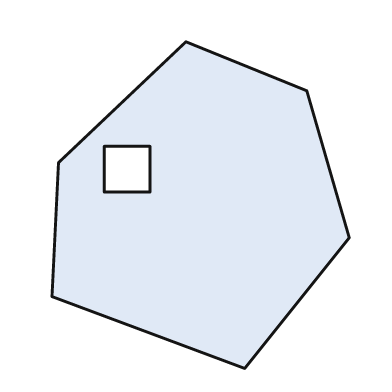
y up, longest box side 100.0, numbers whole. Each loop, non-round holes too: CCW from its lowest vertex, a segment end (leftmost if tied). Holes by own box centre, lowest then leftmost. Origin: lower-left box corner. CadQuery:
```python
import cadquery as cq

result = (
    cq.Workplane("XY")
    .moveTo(59.0, 0.0)
    .lineTo(91.0, 40.0)
    .lineTo(78.0, 85.0)
    .lineTo(41.0, 100.0)
    .lineTo(2.0, 63.0)
    .lineTo(0.0, 22.0)
    .close()
    .moveTo(16.0, 54.0)
    .lineTo(30.0, 54.0)
    .lineTo(30.0, 68.0)
    .lineTo(16.0, 68.0)
    .close()
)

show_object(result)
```